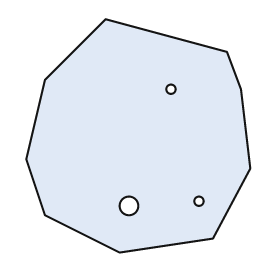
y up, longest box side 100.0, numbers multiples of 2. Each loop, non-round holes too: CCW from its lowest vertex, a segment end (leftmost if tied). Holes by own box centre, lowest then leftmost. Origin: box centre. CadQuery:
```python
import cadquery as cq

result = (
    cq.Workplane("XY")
    .moveTo(-8.0, -50.0)
    .lineTo(32.0, -44.0)
    .lineTo(48.0, -14.0)
    .lineTo(44.0, 20.0)
    .lineTo(38.0, 36.0)
    .lineTo(-14.0, 50.0)
    .lineTo(-40.0, 24.0)
    .lineTo(-48.0, -10.0)
    .lineTo(-40.0, -34.0)
    .close()
    .moveTo(-4.0, -30.0)
    .circle(4.0)
    .moveTo(26.0, -28.0)
    .circle(2.0)
    .moveTo(14.0, 20.0)
    .circle(2.0)
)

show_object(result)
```